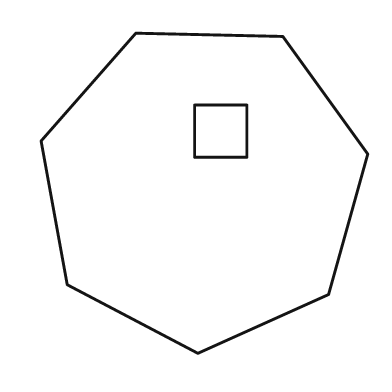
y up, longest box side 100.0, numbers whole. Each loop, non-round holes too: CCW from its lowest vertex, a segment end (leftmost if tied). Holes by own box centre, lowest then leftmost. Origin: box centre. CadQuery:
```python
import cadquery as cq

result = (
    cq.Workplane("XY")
    .moveTo(-2.0, -49.0)
    .lineTo(38.0, -31.0)
    .lineTo(50.0, 12.0)
    .lineTo(24.0, 48.0)
    .lineTo(-21.0, 49.0)
    .lineTo(-50.0, 16.0)
    .lineTo(-42.0, -28.0)
    .close()
    .moveTo(-3.0, 11.0)
    .lineTo(13.0, 11.0)
    .lineTo(13.0, 27.0)
    .lineTo(-3.0, 27.0)
    .close()
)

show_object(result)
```